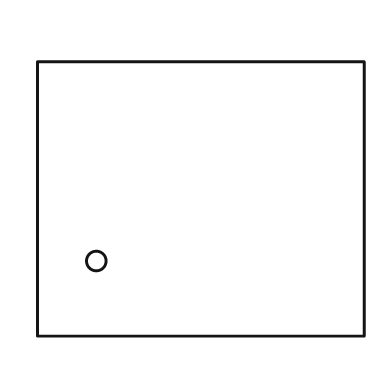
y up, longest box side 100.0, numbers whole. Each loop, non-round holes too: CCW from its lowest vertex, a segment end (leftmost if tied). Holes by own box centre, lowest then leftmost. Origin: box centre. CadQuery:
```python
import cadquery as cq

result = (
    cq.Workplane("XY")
    .moveTo(-50.0, -42.0)
    .lineTo(50.0, -42.0)
    .lineTo(50.0, 42.0)
    .lineTo(-50.0, 42.0)
    .close()
    .moveTo(-32.0, -19.0)
    .circle(3.0)
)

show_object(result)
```